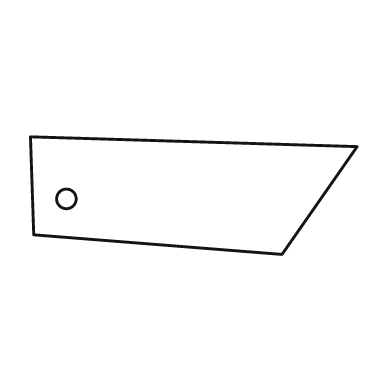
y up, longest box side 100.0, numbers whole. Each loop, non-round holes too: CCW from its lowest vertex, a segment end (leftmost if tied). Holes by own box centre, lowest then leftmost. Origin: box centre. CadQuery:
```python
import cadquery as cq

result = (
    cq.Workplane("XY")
    .moveTo(27.0, -18.0)
    .lineTo(50.0, 15.0)
    .lineTo(-50.0, 18.0)
    .lineTo(-49.0, -12.0)
    .close()
    .moveTo(-39.0, -1.0)
    .circle(3.0)
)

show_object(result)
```